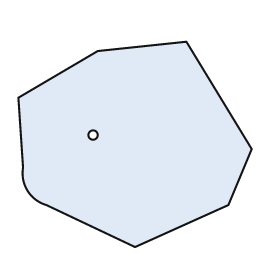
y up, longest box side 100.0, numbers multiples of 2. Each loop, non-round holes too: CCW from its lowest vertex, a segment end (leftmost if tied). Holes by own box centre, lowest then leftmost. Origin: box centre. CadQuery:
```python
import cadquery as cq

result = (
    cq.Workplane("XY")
    .moveTo(0.0, -44.0)
    .lineTo(40.0, -26.0)
    .lineTo(50.0, -2.0)
    .lineTo(22.0, 44.0)
    .lineTo(-16.0, 40.0)
    .lineTo(-50.0, 20.0)
    .lineTo(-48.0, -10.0)
    .threePointArc((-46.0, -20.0), (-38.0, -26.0))
    .close()
    .moveTo(-18.0, 4.0)
    .circle(2.0)
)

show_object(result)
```